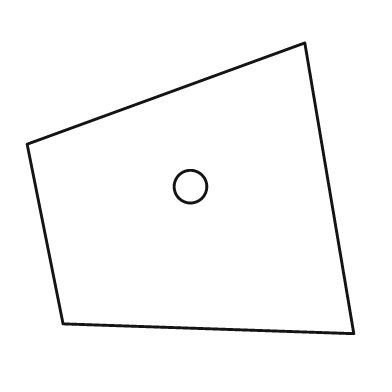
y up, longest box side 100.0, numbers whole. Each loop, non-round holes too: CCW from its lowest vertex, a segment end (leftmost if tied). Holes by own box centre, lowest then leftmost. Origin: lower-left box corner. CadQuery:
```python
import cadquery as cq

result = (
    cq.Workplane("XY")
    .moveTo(100.0, 0.0)
    .lineTo(85.0, 89.0)
    .lineTo(0.0, 58.0)
    .lineTo(11.0, 3.0)
    .close()
    .moveTo(50.0, 45.0)
    .circle(5.0)
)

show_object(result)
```